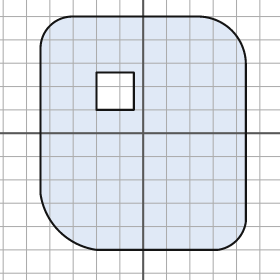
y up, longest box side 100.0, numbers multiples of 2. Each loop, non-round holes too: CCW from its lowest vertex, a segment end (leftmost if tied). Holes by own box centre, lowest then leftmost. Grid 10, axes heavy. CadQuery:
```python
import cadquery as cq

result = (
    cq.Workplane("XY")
    .moveTo(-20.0, -50.0)
    .lineTo(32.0, -50.0)
    .threePointArc((40.0, -46.0), (44.0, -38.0))
    .lineTo(44.0, 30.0)
    .threePointArc((38.0, 44.0), (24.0, 50.0))
    .lineTo(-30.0, 50.0)
    .threePointArc((-40.0, 46.0), (-44.0, 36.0))
    .lineTo(-44.0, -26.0)
    .threePointArc((-36.0, -42.0), (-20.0, -50.0))
    .close()
    .moveTo(-20.0, 10.0)
    .lineTo(-4.0, 10.0)
    .lineTo(-4.0, 26.0)
    .lineTo(-20.0, 26.0)
    .close()
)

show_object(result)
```